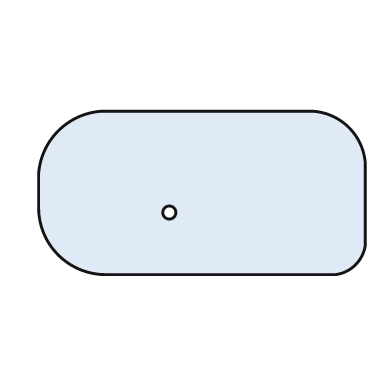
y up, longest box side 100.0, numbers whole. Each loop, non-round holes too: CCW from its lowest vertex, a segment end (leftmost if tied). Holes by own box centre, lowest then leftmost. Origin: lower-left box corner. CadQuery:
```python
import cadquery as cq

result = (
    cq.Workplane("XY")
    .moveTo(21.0, 0.0)
    .lineTo(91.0, 0.0)
    .threePointArc((97.0, 3.0), (100.0, 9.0))
    .lineTo(100.0, 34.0)
    .threePointArc((95.0, 45.0), (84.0, 50.0))
    .lineTo(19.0, 50.0)
    .threePointArc((6.0, 44.0), (0.0, 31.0))
    .lineTo(0.0, 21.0)
    .threePointArc((6.0, 6.0), (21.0, 0.0))
    .close()
    .moveTo(40.0, 19.0)
    .circle(2.0)
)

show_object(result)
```